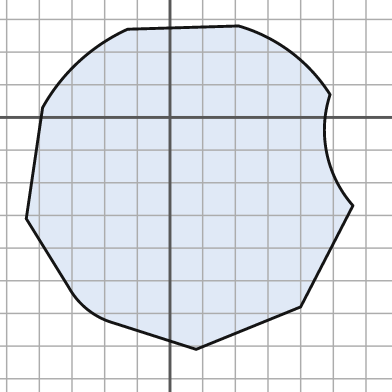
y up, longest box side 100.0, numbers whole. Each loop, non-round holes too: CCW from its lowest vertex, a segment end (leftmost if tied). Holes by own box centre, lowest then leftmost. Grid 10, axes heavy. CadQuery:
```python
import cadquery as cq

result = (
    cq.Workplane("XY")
    .moveTo(8.0, -71.0)
    .lineTo(40.0, -58.0)
    .lineTo(56.0, -27.0)
    .threePointArc((48.0, -11.0), (49.0, 7.0))
    .threePointArc((37.0, 20.0), (21.0, 28.0))
    .lineTo(-13.0, 27.0)
    .threePointArc((-28.0, 17.0), (-39.0, 3.0))
    .lineTo(-44.0, -31.0)
    .lineTo(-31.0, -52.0)
    .threePointArc((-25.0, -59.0), (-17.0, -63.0))
    .close()
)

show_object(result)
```